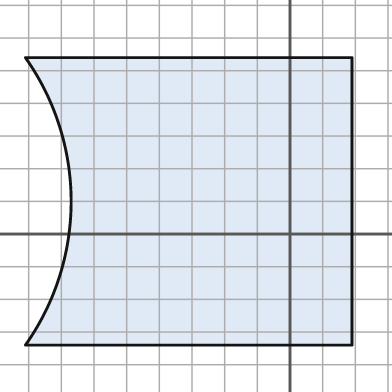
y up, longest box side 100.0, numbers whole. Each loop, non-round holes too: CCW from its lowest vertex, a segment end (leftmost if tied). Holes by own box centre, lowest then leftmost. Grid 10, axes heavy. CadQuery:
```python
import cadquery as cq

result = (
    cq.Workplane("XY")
    .moveTo(-81.0, -34.0)
    .lineTo(19.0, -34.0)
    .lineTo(19.0, 54.0)
    .lineTo(-81.0, 54.0)
    .threePointArc((-67.0, 10.0), (-81.0, -34.0))
    .close()
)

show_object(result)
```